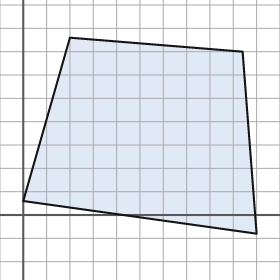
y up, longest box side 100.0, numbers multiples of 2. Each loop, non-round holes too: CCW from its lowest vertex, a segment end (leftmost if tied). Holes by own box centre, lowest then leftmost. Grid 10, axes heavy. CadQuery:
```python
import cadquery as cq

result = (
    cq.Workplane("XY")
    .moveTo(100.0, -8.0)
    .lineTo(94.0, 70.0)
    .lineTo(20.0, 76.0)
    .lineTo(0.0, 6.0)
    .close()
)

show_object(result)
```